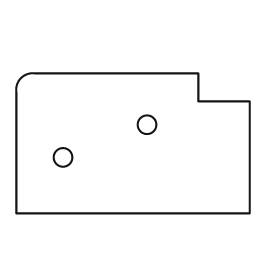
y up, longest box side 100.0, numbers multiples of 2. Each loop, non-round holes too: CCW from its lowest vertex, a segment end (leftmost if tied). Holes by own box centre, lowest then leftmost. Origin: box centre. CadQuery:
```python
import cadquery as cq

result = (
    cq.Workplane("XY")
    .moveTo(-50.0, -30.0)
    .lineTo(50.0, -30.0)
    .lineTo(50.0, 18.0)
    .lineTo(28.0, 18.0)
    .lineTo(28.0, 30.0)
    .lineTo(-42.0, 30.0)
    .threePointArc((-48.0, 28.0), (-50.0, 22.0))
    .close()
    .moveTo(-30.0, -6.0)
    .circle(4.0)
    .moveTo(6.0, 8.0)
    .circle(4.0)
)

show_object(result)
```